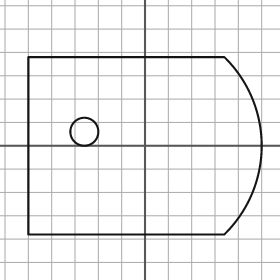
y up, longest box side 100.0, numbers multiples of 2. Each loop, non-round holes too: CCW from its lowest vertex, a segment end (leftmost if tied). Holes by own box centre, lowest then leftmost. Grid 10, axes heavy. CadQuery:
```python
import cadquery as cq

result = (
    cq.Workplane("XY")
    .moveTo(-50.0, -38.0)
    .lineTo(34.0, -38.0)
    .threePointArc((50.0, 0.0), (34.0, 38.0))
    .lineTo(-50.0, 38.0)
    .close()
    .moveTo(-26.0, 6.0)
    .circle(6.0)
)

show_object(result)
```